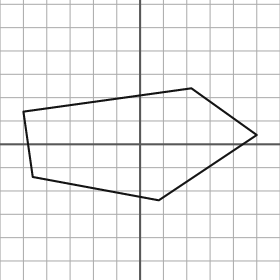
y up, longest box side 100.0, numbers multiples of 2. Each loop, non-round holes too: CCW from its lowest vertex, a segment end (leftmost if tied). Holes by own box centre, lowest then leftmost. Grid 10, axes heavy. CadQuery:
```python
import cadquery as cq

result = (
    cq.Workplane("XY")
    .moveTo(8.0, -24.0)
    .lineTo(50.0, 4.0)
    .lineTo(22.0, 24.0)
    .lineTo(-50.0, 14.0)
    .lineTo(-46.0, -14.0)
    .close()
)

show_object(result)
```